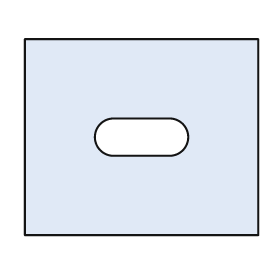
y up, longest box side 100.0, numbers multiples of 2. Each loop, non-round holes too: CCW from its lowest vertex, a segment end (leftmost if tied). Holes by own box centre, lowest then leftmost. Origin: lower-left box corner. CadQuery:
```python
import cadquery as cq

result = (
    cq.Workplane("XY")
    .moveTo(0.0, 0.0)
    .lineTo(100.0, 0.0)
    .lineTo(100.0, 84.0)
    .lineTo(0.0, 84.0)
    .close()
    .moveTo(38.0, 34.0)
    .lineTo(62.0, 34.0)
    .threePointArc((70.0, 42.0), (62.0, 50.0))
    .lineTo(38.0, 50.0)
    .threePointArc((30.0, 42.0), (38.0, 34.0))
    .close()
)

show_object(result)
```